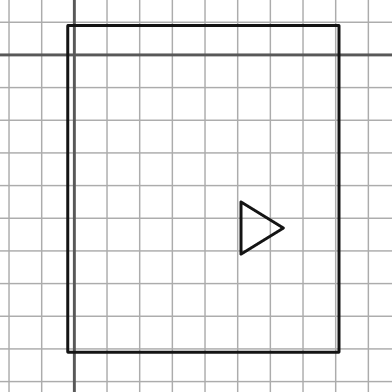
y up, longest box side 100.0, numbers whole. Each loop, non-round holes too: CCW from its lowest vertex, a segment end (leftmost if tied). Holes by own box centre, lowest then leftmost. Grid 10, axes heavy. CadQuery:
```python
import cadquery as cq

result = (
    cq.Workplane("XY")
    .moveTo(-2.0, -91.0)
    .lineTo(81.0, -91.0)
    .lineTo(81.0, 9.0)
    .lineTo(-2.0, 9.0)
    .close()
    .moveTo(51.0, -61.0)
    .lineTo(64.0, -53.0)
    .lineTo(51.0, -45.0)
    .close()
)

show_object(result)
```